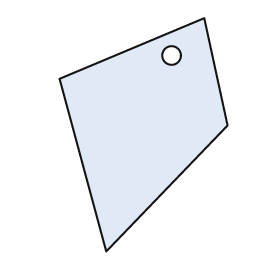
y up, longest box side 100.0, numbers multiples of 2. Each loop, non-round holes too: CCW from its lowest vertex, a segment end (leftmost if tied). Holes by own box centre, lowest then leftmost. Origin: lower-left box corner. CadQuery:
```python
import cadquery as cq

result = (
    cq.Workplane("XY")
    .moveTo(20.0, 0.0)
    .lineTo(72.0, 54.0)
    .lineTo(62.0, 100.0)
    .lineTo(0.0, 74.0)
    .close()
    .moveTo(48.0, 84.0)
    .circle(4.0)
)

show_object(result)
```